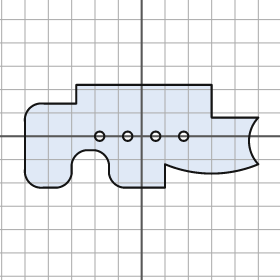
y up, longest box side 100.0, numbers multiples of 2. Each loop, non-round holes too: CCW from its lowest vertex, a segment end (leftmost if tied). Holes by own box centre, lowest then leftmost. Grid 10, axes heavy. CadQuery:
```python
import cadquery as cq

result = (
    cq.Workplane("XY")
    .moveTo(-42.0, -22.0)
    .lineTo(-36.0, -22.0)
    .threePointArc((-32.0, -20.0), (-30.0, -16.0))
    .lineTo(-30.0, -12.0)
    .threePointArc((-28.0, -8.0), (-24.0, -6.0))
    .lineTo(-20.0, -6.0)
    .threePointArc((-16.0, -8.0), (-14.0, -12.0))
    .lineTo(-14.0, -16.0)
    .threePointArc((-12.0, -20.0), (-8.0, -22.0))
    .lineTo(10.0, -22.0)
    .lineTo(10.0, -12.0)
    .threePointArc((30.0, -16.0), (50.0, -12.0))
    .threePointArc((46.0, -2.0), (50.0, 8.0))
    .lineTo(30.0, 8.0)
    .lineTo(30.0, 22.0)
    .lineTo(-28.0, 22.0)
    .lineTo(-28.0, 14.0)
    .lineTo(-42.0, 14.0)
    .threePointArc((-48.0, 12.0), (-50.0, 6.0))
    .lineTo(-50.0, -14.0)
    .threePointArc((-48.0, -20.0), (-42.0, -22.0))
    .close()
    .moveTo(-18.0, 0.0)
    .circle(2.0)
    .moveTo(-6.0, 0.0)
    .circle(2.0)
    .moveTo(6.0, 0.0)
    .circle(2.0)
    .moveTo(18.0, 0.0)
    .circle(2.0)
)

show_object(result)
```